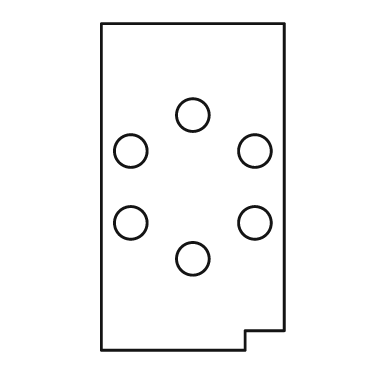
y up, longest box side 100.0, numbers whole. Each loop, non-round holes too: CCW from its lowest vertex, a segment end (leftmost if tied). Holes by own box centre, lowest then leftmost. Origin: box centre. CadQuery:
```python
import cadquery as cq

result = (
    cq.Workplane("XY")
    .moveTo(-28.0, -50.0)
    .lineTo(16.0, -50.0)
    .lineTo(16.0, -44.0)
    .lineTo(28.0, -44.0)
    .lineTo(28.0, 50.0)
    .lineTo(-28.0, 50.0)
    .close()
    .moveTo(0.0, -22.0)
    .circle(5.0)
    .moveTo(-19.0, -11.0)
    .circle(5.0)
    .moveTo(19.0, -11.0)
    .circle(5.0)
    .moveTo(-19.0, 11.0)
    .circle(5.0)
    .moveTo(19.0, 11.0)
    .circle(5.0)
    .moveTo(0.0, 22.0)
    .circle(5.0)
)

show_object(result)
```